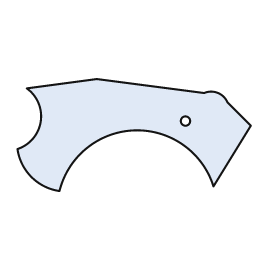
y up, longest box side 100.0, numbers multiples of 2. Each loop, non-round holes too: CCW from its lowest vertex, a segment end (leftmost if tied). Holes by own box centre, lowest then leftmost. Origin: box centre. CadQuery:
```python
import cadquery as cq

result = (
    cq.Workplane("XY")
    .moveTo(-32.0, -24.0)
    .threePointArc((0.0, 2.0), (34.0, -22.0))
    .lineTo(50.0, 4.0)
    .lineTo(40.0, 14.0)
    .threePointArc((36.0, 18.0), (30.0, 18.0))
    .lineTo(-16.0, 24.0)
    .lineTo(-46.0, 20.0)
    .threePointArc((-40.0, 6.0), (-50.0, -6.0))
    .threePointArc((-44.0, -18.0), (-32.0, -24.0))
    .close()
    .moveTo(22.0, 6.0)
    .circle(2.0)
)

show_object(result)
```